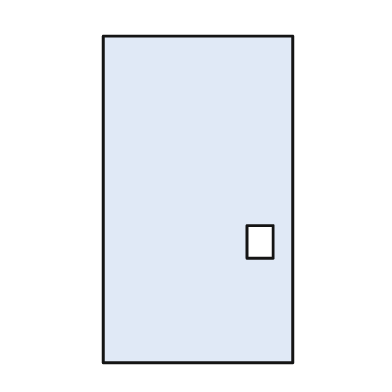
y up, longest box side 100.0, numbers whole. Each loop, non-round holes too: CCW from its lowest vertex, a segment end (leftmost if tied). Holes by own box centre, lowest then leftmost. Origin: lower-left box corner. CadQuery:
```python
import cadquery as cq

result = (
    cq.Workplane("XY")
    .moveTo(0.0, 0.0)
    .lineTo(58.0, 0.0)
    .lineTo(58.0, 100.0)
    .lineTo(0.0, 100.0)
    .close()
    .moveTo(44.0, 32.0)
    .lineTo(52.0, 32.0)
    .lineTo(52.0, 42.0)
    .lineTo(44.0, 42.0)
    .close()
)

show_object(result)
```